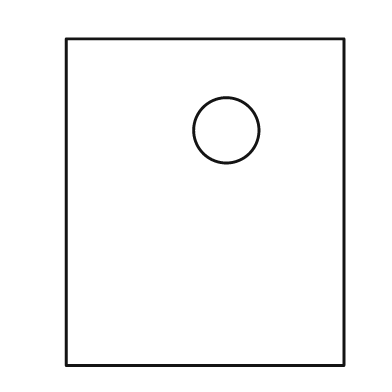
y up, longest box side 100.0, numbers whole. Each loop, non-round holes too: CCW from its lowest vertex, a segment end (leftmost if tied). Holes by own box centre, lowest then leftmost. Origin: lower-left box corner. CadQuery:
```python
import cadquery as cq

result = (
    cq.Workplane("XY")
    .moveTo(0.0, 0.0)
    .lineTo(85.0, 0.0)
    .lineTo(85.0, 100.0)
    .lineTo(0.0, 100.0)
    .close()
    .moveTo(49.0, 72.0)
    .circle(10.0)
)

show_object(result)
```